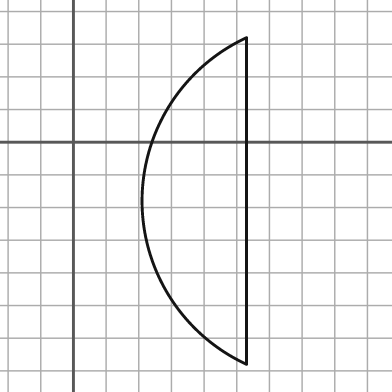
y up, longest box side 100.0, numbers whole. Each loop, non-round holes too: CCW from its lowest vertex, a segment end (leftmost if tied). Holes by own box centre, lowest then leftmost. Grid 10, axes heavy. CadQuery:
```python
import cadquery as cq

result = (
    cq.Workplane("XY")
    .moveTo(53.0, -68.0)
    .lineTo(53.0, 32.0)
    .threePointArc((21.0, -18.0), (53.0, -68.0))
    .close()
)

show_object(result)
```